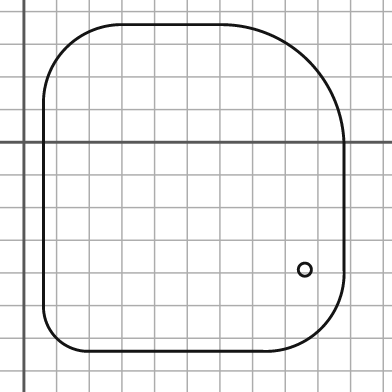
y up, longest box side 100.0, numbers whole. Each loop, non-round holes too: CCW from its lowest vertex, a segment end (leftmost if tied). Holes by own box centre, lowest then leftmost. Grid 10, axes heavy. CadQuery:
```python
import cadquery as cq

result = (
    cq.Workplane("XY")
    .moveTo(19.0, -64.0)
    .lineTo(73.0, -64.0)
    .threePointArc((91.0, -57.0), (98.0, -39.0))
    .lineTo(98.0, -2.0)
    .threePointArc((87.0, 25.0), (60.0, 36.0))
    .lineTo(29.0, 36.0)
    .threePointArc((13.0, 29.0), (6.0, 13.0))
    .lineTo(6.0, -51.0)
    .threePointArc((10.0, -60.0), (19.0, -64.0))
    .close()
    .moveTo(86.0, -39.0)
    .circle(2.0)
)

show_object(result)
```